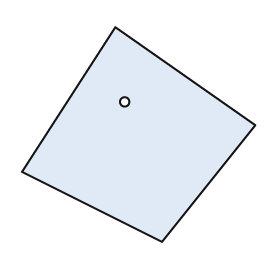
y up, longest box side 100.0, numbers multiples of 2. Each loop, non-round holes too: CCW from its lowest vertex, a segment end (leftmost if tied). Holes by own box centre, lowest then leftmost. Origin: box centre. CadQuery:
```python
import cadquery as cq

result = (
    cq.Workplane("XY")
    .moveTo(10.0, -46.0)
    .lineTo(50.0, 4.0)
    .lineTo(-10.0, 46.0)
    .lineTo(-50.0, -16.0)
    .close()
    .moveTo(-6.0, 14.0)
    .circle(2.0)
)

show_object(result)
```